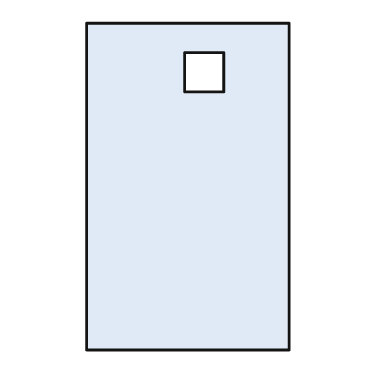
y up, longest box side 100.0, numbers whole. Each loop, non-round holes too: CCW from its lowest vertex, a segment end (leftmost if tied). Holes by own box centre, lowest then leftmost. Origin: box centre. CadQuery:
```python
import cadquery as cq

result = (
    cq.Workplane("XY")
    .moveTo(-31.0, -50.0)
    .lineTo(31.0, -50.0)
    .lineTo(31.0, 50.0)
    .lineTo(-31.0, 50.0)
    .close()
    .moveTo(-1.0, 29.0)
    .lineTo(11.0, 29.0)
    .lineTo(11.0, 41.0)
    .lineTo(-1.0, 41.0)
    .close()
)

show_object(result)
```